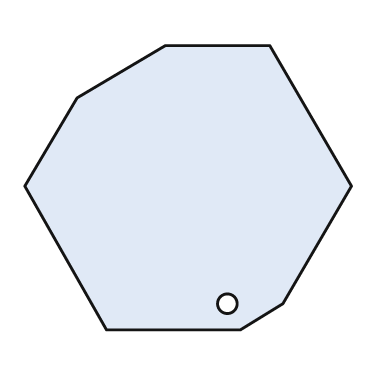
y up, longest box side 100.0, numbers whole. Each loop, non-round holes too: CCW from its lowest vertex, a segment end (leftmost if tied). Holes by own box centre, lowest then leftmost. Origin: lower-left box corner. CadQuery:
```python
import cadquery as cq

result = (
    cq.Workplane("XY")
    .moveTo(25.0, 0.0)
    .lineTo(66.0, 0.0)
    .lineTo(79.0, 8.0)
    .lineTo(100.0, 44.0)
    .lineTo(75.0, 87.0)
    .lineTo(43.0, 87.0)
    .lineTo(16.0, 71.0)
    .lineTo(0.0, 44.0)
    .close()
    .moveTo(62.0, 8.0)
    .circle(3.0)
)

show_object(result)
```